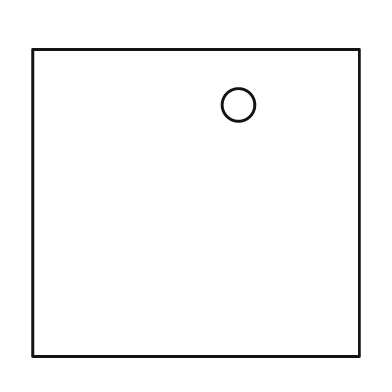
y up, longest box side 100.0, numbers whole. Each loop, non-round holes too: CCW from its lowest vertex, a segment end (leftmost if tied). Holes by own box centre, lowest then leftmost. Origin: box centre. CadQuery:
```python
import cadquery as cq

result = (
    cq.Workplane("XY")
    .moveTo(-50.0, -47.0)
    .lineTo(50.0, -47.0)
    .lineTo(50.0, 47.0)
    .lineTo(-50.0, 47.0)
    .close()
    .moveTo(13.0, 30.0)
    .circle(5.0)
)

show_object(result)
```